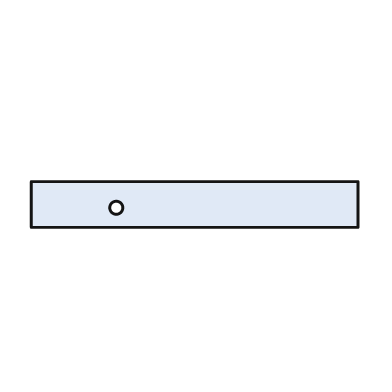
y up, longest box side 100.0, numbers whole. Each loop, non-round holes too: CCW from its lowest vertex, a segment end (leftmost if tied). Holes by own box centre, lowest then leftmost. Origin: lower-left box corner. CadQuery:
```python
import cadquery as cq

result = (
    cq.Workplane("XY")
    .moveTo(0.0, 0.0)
    .lineTo(100.0, 0.0)
    .lineTo(100.0, 14.0)
    .lineTo(0.0, 14.0)
    .close()
    .moveTo(26.0, 6.0)
    .circle(2.0)
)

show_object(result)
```